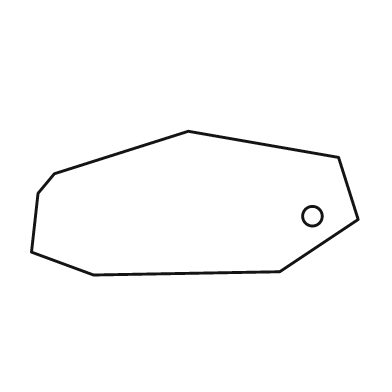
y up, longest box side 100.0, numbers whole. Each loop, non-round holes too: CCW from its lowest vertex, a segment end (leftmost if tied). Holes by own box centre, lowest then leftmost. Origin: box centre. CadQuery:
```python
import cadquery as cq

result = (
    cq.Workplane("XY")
    .moveTo(-31.0, -22.0)
    .lineTo(26.0, -21.0)
    .lineTo(50.0, -5.0)
    .lineTo(44.0, 14.0)
    .lineTo(-2.0, 22.0)
    .lineTo(-43.0, 9.0)
    .lineTo(-48.0, 3.0)
    .lineTo(-50.0, -15.0)
    .close()
    .moveTo(36.0, -4.0)
    .circle(3.0)
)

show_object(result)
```